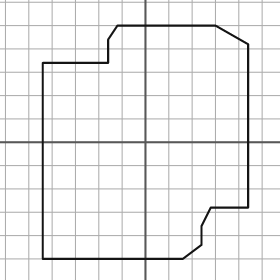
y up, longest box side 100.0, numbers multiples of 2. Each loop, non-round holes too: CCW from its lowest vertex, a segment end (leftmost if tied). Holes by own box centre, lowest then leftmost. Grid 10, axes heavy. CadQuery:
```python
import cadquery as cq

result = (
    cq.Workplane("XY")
    .moveTo(-44.0, -50.0)
    .lineTo(16.0, -50.0)
    .lineTo(24.0, -44.0)
    .lineTo(24.0, -36.0)
    .lineTo(28.0, -28.0)
    .lineTo(44.0, -28.0)
    .lineTo(44.0, 42.0)
    .lineTo(30.0, 50.0)
    .lineTo(-12.0, 50.0)
    .lineTo(-16.0, 44.0)
    .lineTo(-16.0, 34.0)
    .lineTo(-44.0, 34.0)
    .close()
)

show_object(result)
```